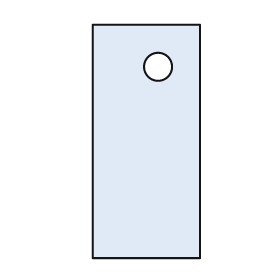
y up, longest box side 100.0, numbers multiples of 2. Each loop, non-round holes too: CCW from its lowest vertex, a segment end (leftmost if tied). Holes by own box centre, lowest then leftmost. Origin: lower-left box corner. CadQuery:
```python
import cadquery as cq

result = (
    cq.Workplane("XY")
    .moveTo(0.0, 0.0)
    .lineTo(46.0, 0.0)
    .lineTo(46.0, 100.0)
    .lineTo(0.0, 100.0)
    .close()
    .moveTo(28.0, 82.0)
    .circle(6.0)
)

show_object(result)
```